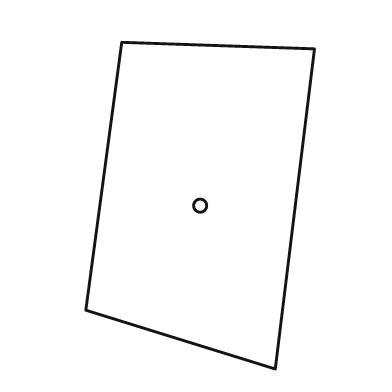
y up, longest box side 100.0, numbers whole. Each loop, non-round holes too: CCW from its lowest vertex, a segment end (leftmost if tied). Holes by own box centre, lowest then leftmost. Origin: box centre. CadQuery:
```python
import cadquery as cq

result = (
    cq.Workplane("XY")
    .moveTo(23.0, -50.0)
    .lineTo(35.0, 48.0)
    .lineTo(-24.0, 50.0)
    .lineTo(-35.0, -32.0)
    .close()
    .moveTo(0.0, 0.0)
    .circle(2.0)
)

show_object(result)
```